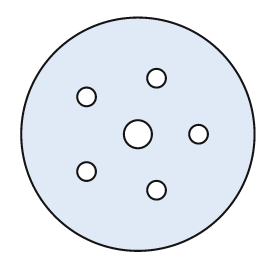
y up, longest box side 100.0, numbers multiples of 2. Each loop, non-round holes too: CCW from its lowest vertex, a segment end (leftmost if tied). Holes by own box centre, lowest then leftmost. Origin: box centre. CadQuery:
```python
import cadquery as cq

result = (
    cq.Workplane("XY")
    .moveTo(0.0, 0.0)
    .circle(50.0)
    .moveTo(8.0, -24.0)
    .circle(4.0)
    .moveTo(-22.0, -16.0)
    .circle(4.0)
    .moveTo(0.0, 0.0)
    .circle(6.0)
    .moveTo(26.0, 0.0)
    .circle(4.0)
    .moveTo(-22.0, 16.0)
    .circle(4.0)
    .moveTo(8.0, 24.0)
    .circle(4.0)
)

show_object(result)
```